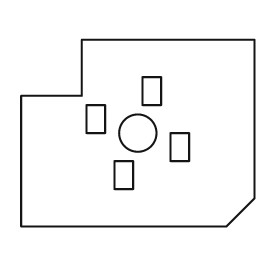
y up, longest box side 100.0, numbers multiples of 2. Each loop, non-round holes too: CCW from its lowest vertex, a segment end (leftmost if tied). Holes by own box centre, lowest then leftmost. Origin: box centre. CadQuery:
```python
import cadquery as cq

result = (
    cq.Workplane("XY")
    .moveTo(-50.0, -40.0)
    .lineTo(38.0, -40.0)
    .lineTo(50.0, -28.0)
    .lineTo(50.0, 40.0)
    .lineTo(-24.0, 40.0)
    .lineTo(-24.0, 16.0)
    .lineTo(-50.0, 16.0)
    .close()
    .moveTo(-10.0, -24.0)
    .lineTo(-2.0, -24.0)
    .lineTo(-2.0, -12.0)
    .lineTo(-10.0, -12.0)
    .close()
    .moveTo(14.0, -12.0)
    .lineTo(22.0, -12.0)
    .lineTo(22.0, 0.0)
    .lineTo(14.0, 0.0)
    .close()
    .moveTo(0.0, 0.0)
    .circle(8.0)
    .moveTo(-22.0, 0.0)
    .lineTo(-14.0, 0.0)
    .lineTo(-14.0, 12.0)
    .lineTo(-22.0, 12.0)
    .close()
    .moveTo(2.0, 12.0)
    .lineTo(10.0, 12.0)
    .lineTo(10.0, 24.0)
    .lineTo(2.0, 24.0)
    .close()
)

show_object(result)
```